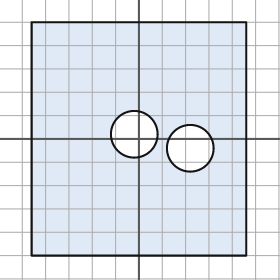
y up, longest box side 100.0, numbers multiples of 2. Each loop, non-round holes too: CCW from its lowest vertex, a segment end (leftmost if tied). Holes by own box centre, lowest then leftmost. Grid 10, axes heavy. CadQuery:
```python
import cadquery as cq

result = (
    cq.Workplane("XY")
    .moveTo(-46.0, -50.0)
    .lineTo(46.0, -50.0)
    .lineTo(46.0, 50.0)
    .lineTo(-46.0, 50.0)
    .close()
    .moveTo(22.0, -4.0)
    .circle(10.0)
    .moveTo(-2.0, 2.0)
    .circle(10.0)
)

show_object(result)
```